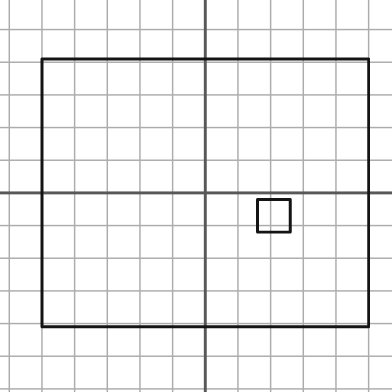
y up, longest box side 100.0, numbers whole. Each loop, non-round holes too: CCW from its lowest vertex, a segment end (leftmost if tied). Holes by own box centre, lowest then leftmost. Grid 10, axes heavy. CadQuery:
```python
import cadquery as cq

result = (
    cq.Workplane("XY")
    .moveTo(-50.0, -41.0)
    .lineTo(50.0, -41.0)
    .lineTo(50.0, 41.0)
    .lineTo(-50.0, 41.0)
    .close()
    .moveTo(16.0, -12.0)
    .lineTo(26.0, -12.0)
    .lineTo(26.0, -2.0)
    .lineTo(16.0, -2.0)
    .close()
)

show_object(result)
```